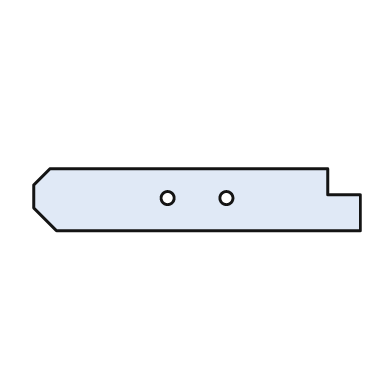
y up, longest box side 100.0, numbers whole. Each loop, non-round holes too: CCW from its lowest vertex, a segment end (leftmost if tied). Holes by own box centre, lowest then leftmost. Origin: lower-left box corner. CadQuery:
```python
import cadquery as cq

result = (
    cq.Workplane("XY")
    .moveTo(7.0, 0.0)
    .lineTo(100.0, 0.0)
    .lineTo(100.0, 11.0)
    .lineTo(90.0, 11.0)
    .lineTo(90.0, 19.0)
    .lineTo(5.0, 19.0)
    .lineTo(0.0, 14.0)
    .lineTo(0.0, 7.0)
    .close()
    .moveTo(41.0, 10.0)
    .circle(2.0)
    .moveTo(59.0, 10.0)
    .circle(2.0)
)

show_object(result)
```